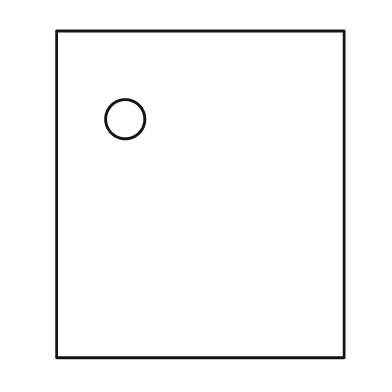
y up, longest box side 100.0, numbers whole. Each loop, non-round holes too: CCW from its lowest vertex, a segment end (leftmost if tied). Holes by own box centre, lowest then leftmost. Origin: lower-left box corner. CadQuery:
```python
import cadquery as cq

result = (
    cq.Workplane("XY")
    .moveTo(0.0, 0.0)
    .lineTo(88.0, 0.0)
    .lineTo(88.0, 100.0)
    .lineTo(0.0, 100.0)
    .close()
    .moveTo(21.0, 73.0)
    .circle(6.0)
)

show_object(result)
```